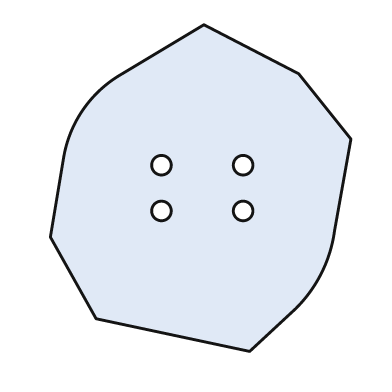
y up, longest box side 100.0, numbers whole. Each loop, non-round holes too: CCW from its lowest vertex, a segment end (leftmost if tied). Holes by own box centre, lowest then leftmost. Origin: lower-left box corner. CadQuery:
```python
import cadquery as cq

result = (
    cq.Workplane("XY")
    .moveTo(61.0, 0.0)
    .lineTo(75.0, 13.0)
    .threePointArc((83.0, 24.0), (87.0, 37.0))
    .lineTo(92.0, 65.0)
    .lineTo(76.0, 85.0)
    .lineTo(47.0, 100.0)
    .lineTo(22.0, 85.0)
    .threePointArc((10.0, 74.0), (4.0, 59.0))
    .lineTo(0.0, 35.0)
    .lineTo(14.0, 10.0)
    .close()
    .moveTo(34.0, 43.0)
    .circle(3.0)
    .moveTo(59.0, 43.0)
    .circle(3.0)
    .moveTo(34.0, 57.0)
    .circle(3.0)
    .moveTo(59.0, 57.0)
    .circle(3.0)
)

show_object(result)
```